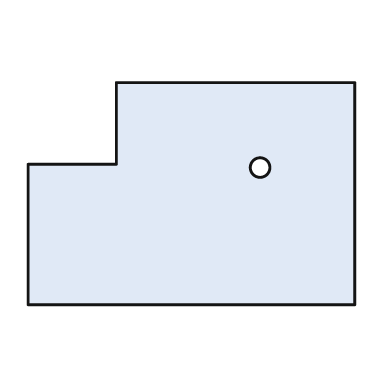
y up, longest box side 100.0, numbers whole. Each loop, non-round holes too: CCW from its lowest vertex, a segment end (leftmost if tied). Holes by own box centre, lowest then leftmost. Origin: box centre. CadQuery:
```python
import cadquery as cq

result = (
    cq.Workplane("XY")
    .moveTo(-50.0, -34.0)
    .lineTo(50.0, -34.0)
    .lineTo(50.0, 34.0)
    .lineTo(-23.0, 34.0)
    .lineTo(-23.0, 9.0)
    .lineTo(-50.0, 9.0)
    .close()
    .moveTo(21.0, 8.0)
    .circle(3.0)
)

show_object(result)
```